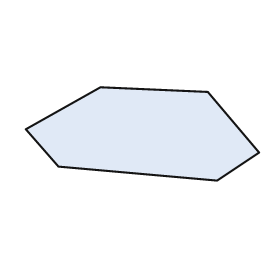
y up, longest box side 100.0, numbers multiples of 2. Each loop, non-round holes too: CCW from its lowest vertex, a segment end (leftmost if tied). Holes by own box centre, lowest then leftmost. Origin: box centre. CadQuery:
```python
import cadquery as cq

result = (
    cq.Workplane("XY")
    .moveTo(32.0, -20.0)
    .lineTo(50.0, -8.0)
    .lineTo(28.0, 18.0)
    .lineTo(-18.0, 20.0)
    .lineTo(-50.0, 2.0)
    .lineTo(-36.0, -14.0)
    .close()
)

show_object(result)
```